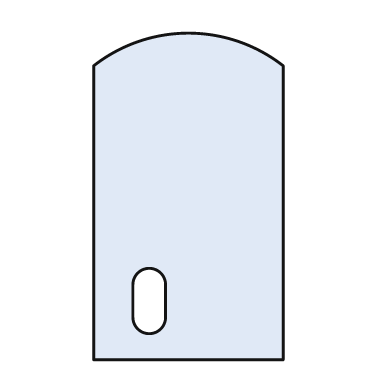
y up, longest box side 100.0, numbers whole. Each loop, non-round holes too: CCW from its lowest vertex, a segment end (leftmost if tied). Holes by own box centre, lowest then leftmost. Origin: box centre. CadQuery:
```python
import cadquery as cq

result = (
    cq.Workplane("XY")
    .moveTo(-29.0, -50.0)
    .lineTo(29.0, -50.0)
    .lineTo(29.0, 40.0)
    .threePointArc((0.0, 50.0), (-29.0, 40.0))
    .close()
    .moveTo(-17.0, -37.0)
    .threePointArc((-12.0, -42.0), (-7.0, -37.0))
    .lineTo(-7.0, -27.0)
    .threePointArc((-12.0, -22.0), (-17.0, -27.0))
    .close()
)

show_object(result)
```